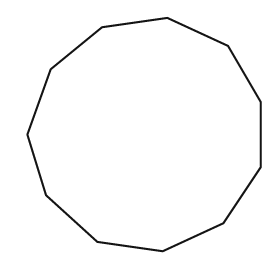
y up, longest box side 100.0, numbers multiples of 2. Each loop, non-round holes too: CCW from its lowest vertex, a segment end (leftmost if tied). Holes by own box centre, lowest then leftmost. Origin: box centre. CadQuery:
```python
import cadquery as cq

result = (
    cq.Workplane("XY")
    .moveTo(8.0, -50.0)
    .lineTo(34.0, -38.0)
    .lineTo(50.0, -14.0)
    .lineTo(50.0, 14.0)
    .lineTo(36.0, 38.0)
    .lineTo(10.0, 50.0)
    .lineTo(-18.0, 46.0)
    .lineTo(-40.0, 28.0)
    .lineTo(-50.0, 0.0)
    .lineTo(-42.0, -26.0)
    .lineTo(-20.0, -46.0)
    .close()
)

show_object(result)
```